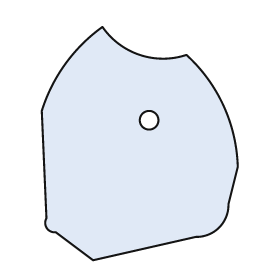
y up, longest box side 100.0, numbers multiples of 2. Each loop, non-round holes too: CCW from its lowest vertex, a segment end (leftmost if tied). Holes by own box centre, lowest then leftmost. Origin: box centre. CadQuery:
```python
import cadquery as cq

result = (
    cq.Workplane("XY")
    .moveTo(-20.0, -50.0)
    .lineTo(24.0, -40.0)
    .threePointArc((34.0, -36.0), (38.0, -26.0))
    .lineTo(42.0, -10.0)
    .threePointArc((36.0, 16.0), (20.0, 38.0))
    .threePointArc((0.0, 38.0), (-16.0, 50.0))
    .threePointArc((-32.0, 34.0), (-42.0, 14.0))
    .lineTo(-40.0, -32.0)
    .threePointArc((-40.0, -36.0), (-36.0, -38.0))
    .close()
    .moveTo(4.0, 10.0)
    .circle(4.0)
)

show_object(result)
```